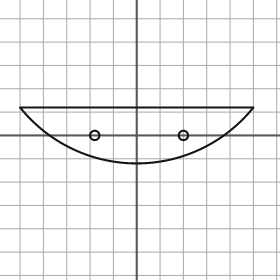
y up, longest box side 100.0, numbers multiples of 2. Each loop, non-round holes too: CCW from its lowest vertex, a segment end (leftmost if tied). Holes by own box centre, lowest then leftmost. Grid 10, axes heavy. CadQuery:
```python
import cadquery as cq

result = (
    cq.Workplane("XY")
    .moveTo(-50.0, 12.0)
    .threePointArc((0.0, -12.0), (50.0, 12.0))
    .close()
    .moveTo(-18.0, 0.0)
    .circle(2.0)
    .moveTo(20.0, 0.0)
    .circle(2.0)
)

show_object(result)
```